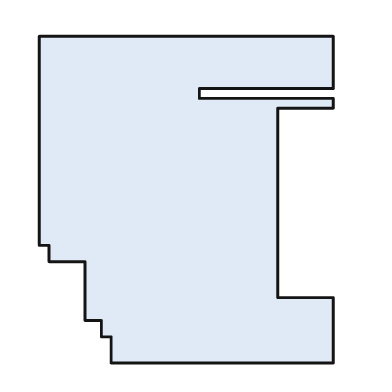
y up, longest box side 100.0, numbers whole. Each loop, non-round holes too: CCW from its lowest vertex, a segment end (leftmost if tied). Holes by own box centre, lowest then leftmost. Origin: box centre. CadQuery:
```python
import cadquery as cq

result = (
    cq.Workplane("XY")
    .moveTo(-23.0, -50.0)
    .lineTo(45.0, -50.0)
    .lineTo(45.0, -30.0)
    .lineTo(28.0, -30.0)
    .lineTo(28.0, 28.0)
    .lineTo(45.0, 28.0)
    .lineTo(45.0, 31.0)
    .lineTo(4.0, 31.0)
    .lineTo(4.0, 34.0)
    .lineTo(45.0, 34.0)
    .lineTo(45.0, 50.0)
    .lineTo(-45.0, 50.0)
    .lineTo(-45.0, -14.0)
    .lineTo(-42.0, -14.0)
    .lineTo(-42.0, -19.0)
    .lineTo(-31.0, -19.0)
    .lineTo(-31.0, -37.0)
    .lineTo(-26.0, -37.0)
    .lineTo(-26.0, -42.0)
    .lineTo(-23.0, -42.0)
    .close()
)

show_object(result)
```